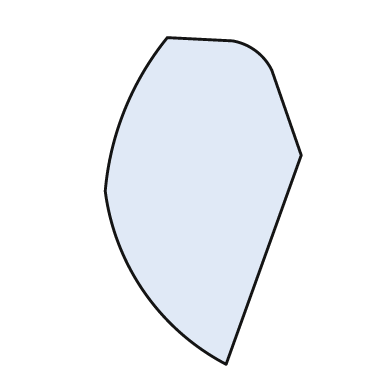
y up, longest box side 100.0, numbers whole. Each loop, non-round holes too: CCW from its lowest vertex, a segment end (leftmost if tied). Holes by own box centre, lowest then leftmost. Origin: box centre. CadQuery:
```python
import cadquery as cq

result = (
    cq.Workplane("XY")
    .moveTo(7.0, -50.0)
    .lineTo(30.0, 14.0)
    .lineTo(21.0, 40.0)
    .threePointArc((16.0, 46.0), (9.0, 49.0))
    .lineTo(-11.0, 50.0)
    .threePointArc((-24.0, 28.0), (-30.0, 3.0))
    .threePointArc((-18.0, -28.0), (7.0, -50.0))
    .close()
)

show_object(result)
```